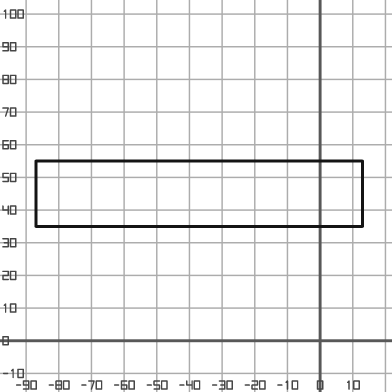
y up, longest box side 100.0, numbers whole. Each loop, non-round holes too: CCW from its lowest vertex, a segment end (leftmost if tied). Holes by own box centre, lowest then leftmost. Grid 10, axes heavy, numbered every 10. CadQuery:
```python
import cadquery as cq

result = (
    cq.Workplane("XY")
    .moveTo(-87.0, 35.0)
    .lineTo(13.0, 35.0)
    .lineTo(13.0, 55.0)
    .lineTo(-87.0, 55.0)
    .close()
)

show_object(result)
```